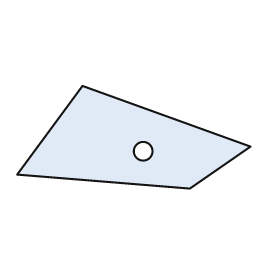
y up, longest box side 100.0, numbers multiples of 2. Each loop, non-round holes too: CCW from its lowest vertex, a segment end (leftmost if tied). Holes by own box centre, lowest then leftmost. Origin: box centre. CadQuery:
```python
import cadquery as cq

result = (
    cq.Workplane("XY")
    .moveTo(24.0, -22.0)
    .lineTo(50.0, -4.0)
    .lineTo(-22.0, 22.0)
    .lineTo(-50.0, -16.0)
    .close()
    .moveTo(4.0, -6.0)
    .circle(4.0)
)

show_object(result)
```